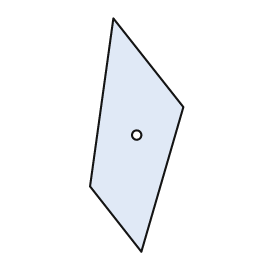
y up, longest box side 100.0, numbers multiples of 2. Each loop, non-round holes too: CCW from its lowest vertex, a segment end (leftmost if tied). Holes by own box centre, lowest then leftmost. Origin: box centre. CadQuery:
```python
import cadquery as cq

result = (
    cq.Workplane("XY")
    .moveTo(2.0, -50.0)
    .lineTo(20.0, 12.0)
    .lineTo(-10.0, 50.0)
    .lineTo(-20.0, -22.0)
    .close()
    .moveTo(0.0, 0.0)
    .circle(2.0)
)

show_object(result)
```